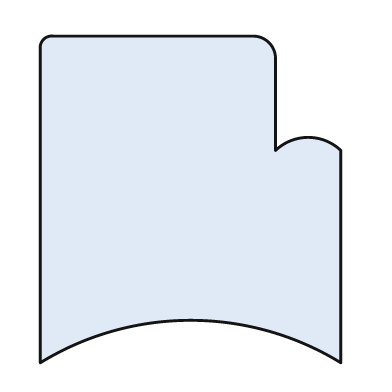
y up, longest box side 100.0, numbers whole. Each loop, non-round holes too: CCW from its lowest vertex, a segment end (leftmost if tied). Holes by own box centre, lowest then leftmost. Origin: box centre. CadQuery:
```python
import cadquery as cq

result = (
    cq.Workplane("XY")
    .moveTo(-46.0, -50.0)
    .threePointArc((0.0, -37.0), (46.0, -50.0))
    .lineTo(46.0, 15.0)
    .threePointArc((36.0, 19.0), (26.0, 15.0))
    .lineTo(26.0, 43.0)
    .threePointArc((24.0, 48.0), (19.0, 50.0))
    .lineTo(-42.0, 50.0)
    .threePointArc((-45.0, 49.0), (-46.0, 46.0))
    .close()
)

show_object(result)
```